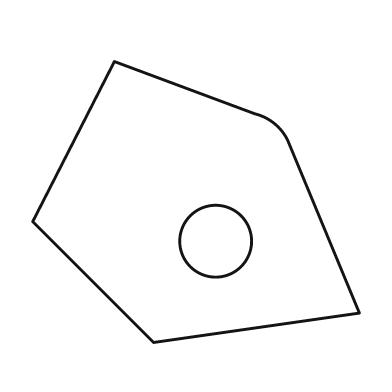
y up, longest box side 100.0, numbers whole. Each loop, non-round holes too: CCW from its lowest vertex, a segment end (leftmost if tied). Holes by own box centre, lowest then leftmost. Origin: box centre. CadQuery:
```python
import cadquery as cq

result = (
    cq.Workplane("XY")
    .moveTo(-13.0, -43.0)
    .lineTo(50.0, -34.0)
    .lineTo(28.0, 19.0)
    .threePointArc((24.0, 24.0), (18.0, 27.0))
    .lineTo(-25.0, 43.0)
    .lineTo(-50.0, -6.0)
    .close()
    .moveTo(6.0, -12.0)
    .circle(11.0)
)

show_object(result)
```